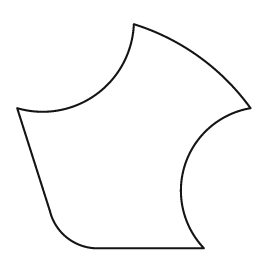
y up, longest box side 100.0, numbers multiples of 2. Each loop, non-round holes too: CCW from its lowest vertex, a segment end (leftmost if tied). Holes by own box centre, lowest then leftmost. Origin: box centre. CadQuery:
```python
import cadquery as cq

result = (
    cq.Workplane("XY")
    .moveTo(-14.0, -48.0)
    .lineTo(30.0, -48.0)
    .threePointArc((22.0, -12.0), (50.0, 12.0))
    .threePointArc((28.0, 34.0), (0.0, 48.0))
    .threePointArc((-16.0, 18.0), (-50.0, 12.0))
    .lineTo(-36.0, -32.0)
    .threePointArc((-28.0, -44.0), (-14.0, -48.0))
    .close()
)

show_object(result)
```